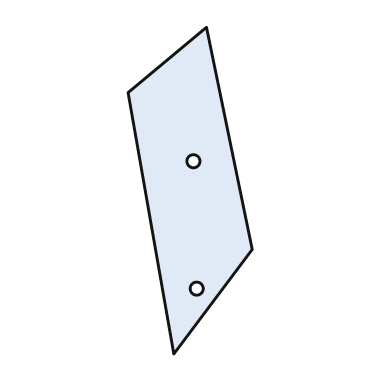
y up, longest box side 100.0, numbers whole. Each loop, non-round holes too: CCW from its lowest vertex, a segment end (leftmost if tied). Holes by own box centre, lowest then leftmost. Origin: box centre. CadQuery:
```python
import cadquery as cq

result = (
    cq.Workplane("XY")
    .moveTo(-5.0, -50.0)
    .lineTo(19.0, -18.0)
    .lineTo(5.0, 50.0)
    .lineTo(-19.0, 30.0)
    .close()
    .moveTo(2.0, -30.0)
    .circle(2.0)
    .moveTo(1.0, 9.0)
    .circle(2.0)
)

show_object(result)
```